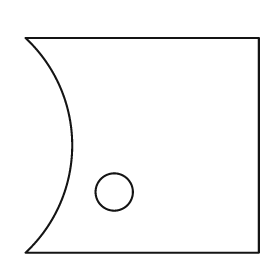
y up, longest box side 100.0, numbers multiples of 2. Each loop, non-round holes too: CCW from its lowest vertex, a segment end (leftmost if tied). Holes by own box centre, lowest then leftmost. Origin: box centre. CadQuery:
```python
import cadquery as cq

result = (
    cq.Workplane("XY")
    .moveTo(-50.0, -46.0)
    .lineTo(50.0, -46.0)
    .lineTo(50.0, 46.0)
    .lineTo(-50.0, 46.0)
    .threePointArc((-30.0, 0.0), (-50.0, -46.0))
    .close()
    .moveTo(-12.0, -20.0)
    .circle(8.0)
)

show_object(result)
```